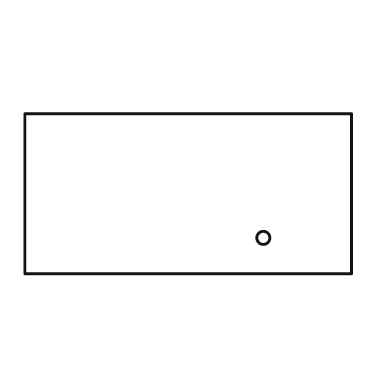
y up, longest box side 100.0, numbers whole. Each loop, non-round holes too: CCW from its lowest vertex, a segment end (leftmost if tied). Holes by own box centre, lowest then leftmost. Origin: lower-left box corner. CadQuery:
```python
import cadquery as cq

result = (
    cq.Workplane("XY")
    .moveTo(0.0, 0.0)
    .lineTo(100.0, 0.0)
    .lineTo(100.0, 49.0)
    .lineTo(0.0, 49.0)
    .close()
    .moveTo(73.0, 11.0)
    .circle(2.0)
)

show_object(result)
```